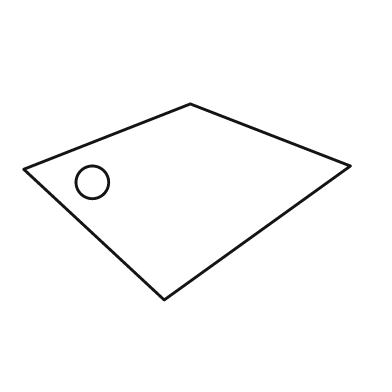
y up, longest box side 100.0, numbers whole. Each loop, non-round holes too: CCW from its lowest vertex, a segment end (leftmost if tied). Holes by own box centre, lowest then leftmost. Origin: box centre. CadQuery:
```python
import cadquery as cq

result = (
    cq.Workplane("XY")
    .moveTo(-7.0, -30.0)
    .lineTo(50.0, 11.0)
    .lineTo(1.0, 30.0)
    .lineTo(-50.0, 10.0)
    .close()
    .moveTo(-29.0, 6.0)
    .circle(5.0)
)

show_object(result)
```